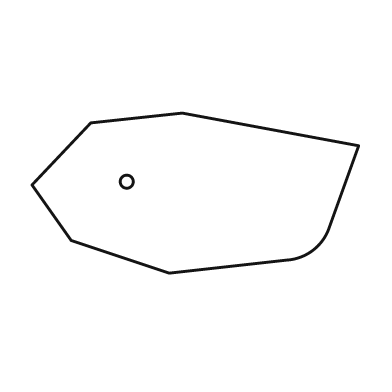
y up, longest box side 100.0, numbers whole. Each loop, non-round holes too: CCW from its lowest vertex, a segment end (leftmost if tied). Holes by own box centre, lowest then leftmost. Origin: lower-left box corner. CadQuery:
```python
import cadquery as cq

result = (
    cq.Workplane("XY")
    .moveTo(42.0, 0.0)
    .lineTo(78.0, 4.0)
    .threePointArc((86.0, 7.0), (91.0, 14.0))
    .lineTo(100.0, 39.0)
    .lineTo(46.0, 49.0)
    .lineTo(18.0, 46.0)
    .lineTo(0.0, 27.0)
    .lineTo(12.0, 10.0)
    .close()
    .moveTo(29.0, 28.0)
    .circle(2.0)
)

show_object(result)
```